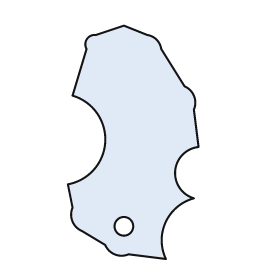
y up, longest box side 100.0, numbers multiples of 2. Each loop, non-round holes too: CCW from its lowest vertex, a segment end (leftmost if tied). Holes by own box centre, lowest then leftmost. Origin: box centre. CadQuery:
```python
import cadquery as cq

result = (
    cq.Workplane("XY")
    .moveTo(14.0, -50.0)
    .threePointArc((14.0, -34.0), (26.0, -24.0))
    .threePointArc((18.0, -12.0), (28.0, -2.0))
    .lineTo(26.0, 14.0)
    .threePointArc((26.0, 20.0), (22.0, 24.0))
    .lineTo(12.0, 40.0)
    .threePointArc((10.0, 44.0), (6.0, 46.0))
    .lineTo(-4.0, 50.0)
    .lineTo(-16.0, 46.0)
    .threePointArc((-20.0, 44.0), (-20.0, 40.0))
    .lineTo(-26.0, 20.0)
    .threePointArc((-12.0, 0.0), (-28.0, -18.0))
    .lineTo(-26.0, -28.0)
    .threePointArc((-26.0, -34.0), (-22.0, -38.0))
    .lineTo(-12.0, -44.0)
    .threePointArc((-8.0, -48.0), (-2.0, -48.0))
    .close()
    .moveTo(-4.0, -36.0)
    .circle(4.0)
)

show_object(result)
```